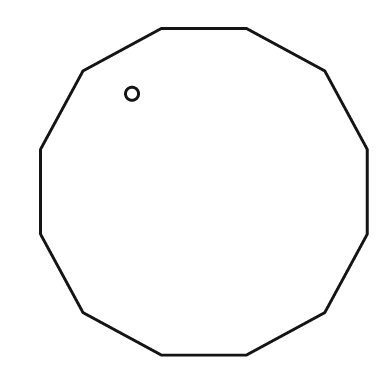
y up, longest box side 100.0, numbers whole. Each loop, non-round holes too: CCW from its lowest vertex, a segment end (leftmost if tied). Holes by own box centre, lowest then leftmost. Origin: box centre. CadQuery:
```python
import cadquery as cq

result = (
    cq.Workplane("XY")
    .moveTo(-13.0, -50.0)
    .lineTo(13.0, -50.0)
    .lineTo(37.0, -37.0)
    .lineTo(50.0, -13.0)
    .lineTo(50.0, 13.0)
    .lineTo(37.0, 37.0)
    .lineTo(13.0, 50.0)
    .lineTo(-13.0, 50.0)
    .lineTo(-37.0, 37.0)
    .lineTo(-50.0, 13.0)
    .lineTo(-50.0, -13.0)
    .lineTo(-37.0, -37.0)
    .close()
    .moveTo(-22.0, 30.0)
    .circle(2.0)
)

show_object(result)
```